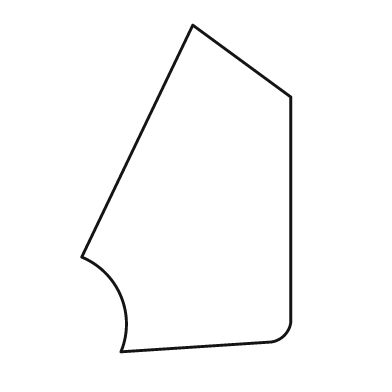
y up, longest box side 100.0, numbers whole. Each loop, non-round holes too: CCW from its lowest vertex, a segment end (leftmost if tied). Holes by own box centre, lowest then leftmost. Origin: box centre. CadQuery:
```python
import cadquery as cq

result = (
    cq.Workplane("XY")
    .moveTo(-20.0, -50.0)
    .lineTo(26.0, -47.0)
    .threePointArc((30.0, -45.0), (32.0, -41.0))
    .lineTo(32.0, 28.0)
    .lineTo(2.0, 50.0)
    .lineTo(-32.0, -21.0)
    .threePointArc((-20.0, -33.0), (-20.0, -50.0))
    .close()
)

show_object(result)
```